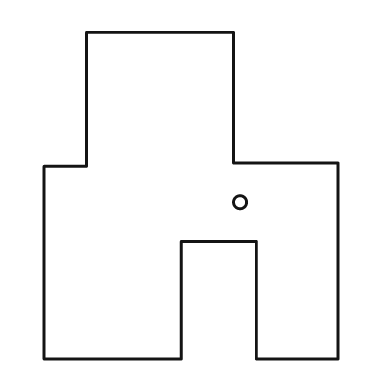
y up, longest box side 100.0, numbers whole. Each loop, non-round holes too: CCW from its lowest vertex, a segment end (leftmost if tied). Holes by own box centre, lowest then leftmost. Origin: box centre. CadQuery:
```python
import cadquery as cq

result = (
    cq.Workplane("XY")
    .moveTo(-45.0, -50.0)
    .lineTo(-3.0, -50.0)
    .lineTo(-3.0, -14.0)
    .lineTo(20.0, -14.0)
    .lineTo(20.0, -50.0)
    .lineTo(45.0, -50.0)
    .lineTo(45.0, 10.0)
    .lineTo(13.0, 10.0)
    .lineTo(13.0, 50.0)
    .lineTo(-32.0, 50.0)
    .lineTo(-32.0, 9.0)
    .lineTo(-45.0, 9.0)
    .close()
    .moveTo(15.0, -2.0)
    .circle(2.0)
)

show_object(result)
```